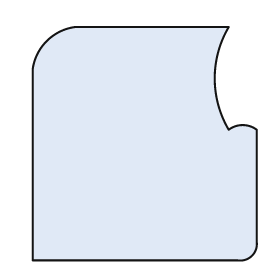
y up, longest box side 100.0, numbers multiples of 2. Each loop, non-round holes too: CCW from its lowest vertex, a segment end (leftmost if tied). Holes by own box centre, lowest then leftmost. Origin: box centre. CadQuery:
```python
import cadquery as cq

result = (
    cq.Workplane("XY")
    .moveTo(-48.0, -50.0)
    .lineTo(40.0, -50.0)
    .threePointArc((46.0, -48.0), (48.0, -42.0))
    .lineTo(48.0, 6.0)
    .threePointArc((42.0, 8.0), (36.0, 6.0))
    .threePointArc((30.0, 28.0), (36.0, 50.0))
    .lineTo(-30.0, 50.0)
    .threePointArc((-42.0, 44.0), (-48.0, 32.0))
    .close()
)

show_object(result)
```